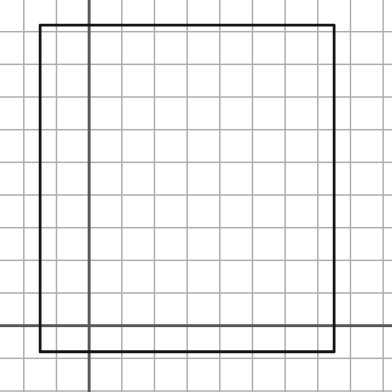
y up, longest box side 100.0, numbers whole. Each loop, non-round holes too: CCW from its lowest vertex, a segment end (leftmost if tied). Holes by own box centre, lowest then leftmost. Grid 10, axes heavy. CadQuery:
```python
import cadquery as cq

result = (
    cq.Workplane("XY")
    .moveTo(-15.0, -8.0)
    .lineTo(75.0, -8.0)
    .lineTo(75.0, 92.0)
    .lineTo(-15.0, 92.0)
    .close()
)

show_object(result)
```